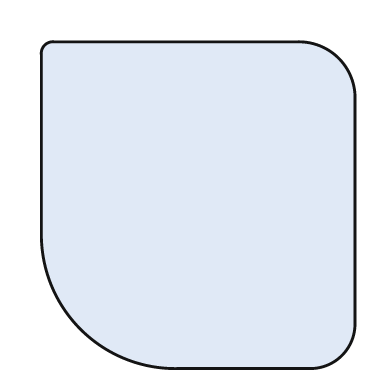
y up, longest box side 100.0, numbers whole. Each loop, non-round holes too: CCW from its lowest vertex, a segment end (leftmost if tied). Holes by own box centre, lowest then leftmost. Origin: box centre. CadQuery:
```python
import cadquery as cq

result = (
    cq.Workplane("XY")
    .moveTo(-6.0, -50.0)
    .lineTo(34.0, -50.0)
    .threePointArc((44.0, -46.0), (48.0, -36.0))
    .lineTo(48.0, 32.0)
    .threePointArc((43.0, 45.0), (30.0, 50.0))
    .lineTo(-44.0, 50.0)
    .threePointArc((-47.0, 49.0), (-48.0, 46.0))
    .lineTo(-48.0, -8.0)
    .threePointArc((-36.0, -38.0), (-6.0, -50.0))
    .close()
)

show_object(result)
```